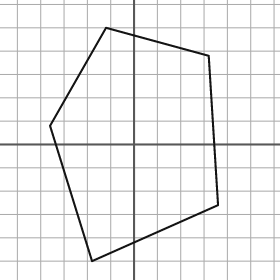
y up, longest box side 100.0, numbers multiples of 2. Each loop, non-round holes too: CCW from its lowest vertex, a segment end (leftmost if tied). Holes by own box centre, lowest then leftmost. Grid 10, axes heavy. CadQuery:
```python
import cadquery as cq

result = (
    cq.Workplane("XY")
    .moveTo(-18.0, -50.0)
    .lineTo(36.0, -26.0)
    .lineTo(32.0, 38.0)
    .lineTo(-12.0, 50.0)
    .lineTo(-36.0, 8.0)
    .close()
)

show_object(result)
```